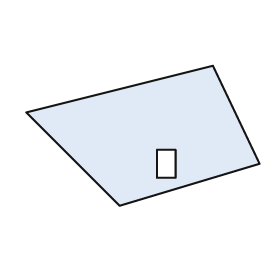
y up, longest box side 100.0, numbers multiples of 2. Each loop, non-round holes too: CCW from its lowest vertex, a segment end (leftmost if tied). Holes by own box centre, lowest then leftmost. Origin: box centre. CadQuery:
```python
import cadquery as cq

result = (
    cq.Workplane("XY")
    .moveTo(-10.0, -30.0)
    .lineTo(50.0, -12.0)
    .lineTo(30.0, 30.0)
    .lineTo(-50.0, 10.0)
    .close()
    .moveTo(6.0, -18.0)
    .lineTo(14.0, -18.0)
    .lineTo(14.0, -6.0)
    .lineTo(6.0, -6.0)
    .close()
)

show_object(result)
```